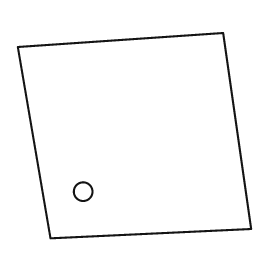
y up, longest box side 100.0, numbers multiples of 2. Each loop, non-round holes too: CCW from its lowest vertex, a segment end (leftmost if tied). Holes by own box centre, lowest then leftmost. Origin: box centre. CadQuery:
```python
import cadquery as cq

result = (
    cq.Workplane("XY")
    .moveTo(-36.0, -44.0)
    .lineTo(50.0, -40.0)
    .lineTo(38.0, 44.0)
    .lineTo(-50.0, 38.0)
    .close()
    .moveTo(-22.0, -24.0)
    .circle(4.0)
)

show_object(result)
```